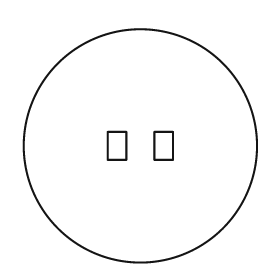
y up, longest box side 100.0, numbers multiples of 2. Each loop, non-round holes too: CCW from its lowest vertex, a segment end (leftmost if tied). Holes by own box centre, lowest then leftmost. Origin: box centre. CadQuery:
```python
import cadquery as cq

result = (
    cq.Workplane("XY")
    .moveTo(0.0, 0.0)
    .circle(50.0)
    .moveTo(-14.0, -6.0)
    .lineTo(-6.0, -6.0)
    .lineTo(-6.0, 6.0)
    .lineTo(-14.0, 6.0)
    .close()
    .moveTo(6.0, -6.0)
    .lineTo(14.0, -6.0)
    .lineTo(14.0, 6.0)
    .lineTo(6.0, 6.0)
    .close()
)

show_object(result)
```